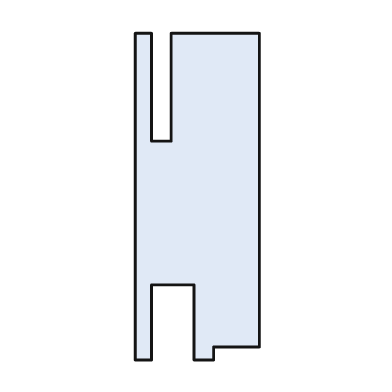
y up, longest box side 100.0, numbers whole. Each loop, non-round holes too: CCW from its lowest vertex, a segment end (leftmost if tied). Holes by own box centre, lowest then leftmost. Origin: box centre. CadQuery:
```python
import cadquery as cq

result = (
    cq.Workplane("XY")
    .moveTo(-19.0, -50.0)
    .lineTo(-14.0, -50.0)
    .lineTo(-14.0, -27.0)
    .lineTo(-1.0, -27.0)
    .lineTo(-1.0, -50.0)
    .lineTo(5.0, -50.0)
    .lineTo(5.0, -46.0)
    .lineTo(19.0, -46.0)
    .lineTo(19.0, 50.0)
    .lineTo(-8.0, 50.0)
    .lineTo(-8.0, 17.0)
    .lineTo(-14.0, 17.0)
    .lineTo(-14.0, 50.0)
    .lineTo(-19.0, 50.0)
    .close()
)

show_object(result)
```